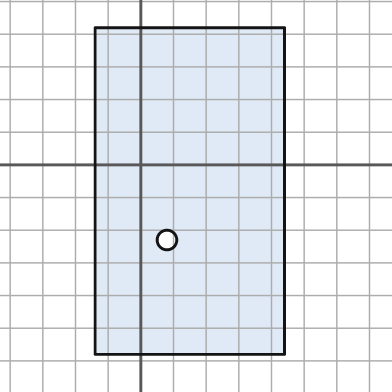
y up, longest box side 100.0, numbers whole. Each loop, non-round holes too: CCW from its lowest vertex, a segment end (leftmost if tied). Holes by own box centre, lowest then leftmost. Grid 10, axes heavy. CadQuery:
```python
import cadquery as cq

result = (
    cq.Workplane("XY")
    .moveTo(-14.0, -58.0)
    .lineTo(44.0, -58.0)
    .lineTo(44.0, 42.0)
    .lineTo(-14.0, 42.0)
    .close()
    .moveTo(8.0, -23.0)
    .circle(3.0)
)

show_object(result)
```